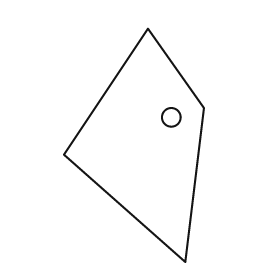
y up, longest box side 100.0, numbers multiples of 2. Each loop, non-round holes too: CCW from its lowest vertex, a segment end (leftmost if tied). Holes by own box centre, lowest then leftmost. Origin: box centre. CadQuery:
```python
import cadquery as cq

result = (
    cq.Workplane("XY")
    .moveTo(22.0, -50.0)
    .lineTo(30.0, 16.0)
    .lineTo(6.0, 50.0)
    .lineTo(-30.0, -4.0)
    .close()
    .moveTo(16.0, 12.0)
    .circle(4.0)
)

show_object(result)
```